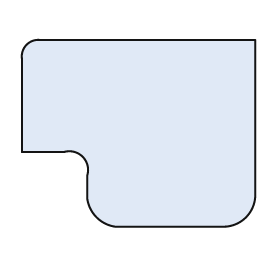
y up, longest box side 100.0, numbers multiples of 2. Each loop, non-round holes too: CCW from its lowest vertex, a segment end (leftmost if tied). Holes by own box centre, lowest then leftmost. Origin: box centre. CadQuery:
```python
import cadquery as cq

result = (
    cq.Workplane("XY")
    .moveTo(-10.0, -40.0)
    .lineTo(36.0, -40.0)
    .threePointArc((46.0, -36.0), (50.0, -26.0))
    .lineTo(50.0, 40.0)
    .lineTo(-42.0, 40.0)
    .threePointArc((-48.0, 38.0), (-50.0, 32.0))
    .lineTo(-50.0, -8.0)
    .lineTo(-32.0, -8.0)
    .threePointArc((-24.0, -10.0), (-22.0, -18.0))
    .lineTo(-22.0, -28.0)
    .threePointArc((-18.0, -36.0), (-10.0, -40.0))
    .close()
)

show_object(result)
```